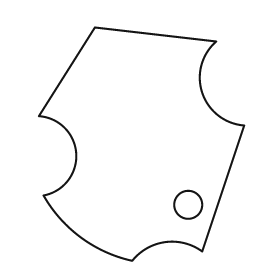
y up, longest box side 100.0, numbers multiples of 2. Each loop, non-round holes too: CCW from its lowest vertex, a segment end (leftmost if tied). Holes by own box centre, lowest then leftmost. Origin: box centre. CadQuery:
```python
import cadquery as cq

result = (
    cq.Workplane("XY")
    .moveTo(-4.0, -50.0)
    .threePointArc((10.0, -42.0), (26.0, -46.0))
    .lineTo(44.0, 8.0)
    .threePointArc((26.0, 22.0), (32.0, 44.0))
    .lineTo(-20.0, 50.0)
    .lineTo(-44.0, 12.0)
    .threePointArc((-28.0, -4.0), (-42.0, -22.0))
    .threePointArc((-26.0, -40.0), (-4.0, -50.0))
    .close()
    .moveTo(20.0, -26.0)
    .circle(6.0)
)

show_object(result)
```